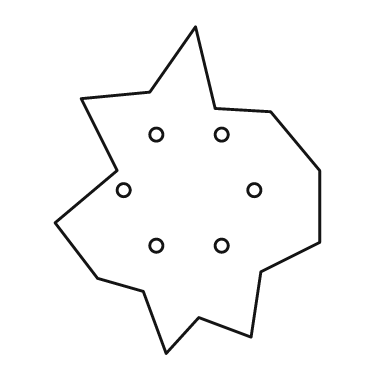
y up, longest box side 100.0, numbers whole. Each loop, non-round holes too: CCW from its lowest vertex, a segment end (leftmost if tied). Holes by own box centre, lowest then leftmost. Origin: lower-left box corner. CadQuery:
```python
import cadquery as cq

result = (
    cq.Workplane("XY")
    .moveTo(34.0, 0.0)
    .lineTo(44.0, 11.0)
    .lineTo(60.0, 5.0)
    .lineTo(63.0, 25.0)
    .lineTo(81.0, 34.0)
    .lineTo(81.0, 56.0)
    .lineTo(66.0, 74.0)
    .lineTo(49.0, 75.0)
    .lineTo(43.0, 100.0)
    .lineTo(29.0, 80.0)
    .lineTo(8.0, 78.0)
    .lineTo(19.0, 56.0)
    .lineTo(0.0, 40.0)
    .lineTo(13.0, 23.0)
    .lineTo(27.0, 19.0)
    .close()
    .moveTo(31.0, 33.0)
    .circle(2.0)
    .moveTo(51.0, 33.0)
    .circle(2.0)
    .moveTo(21.0, 50.0)
    .circle(2.0)
    .moveTo(61.0, 50.0)
    .circle(2.0)
    .moveTo(31.0, 67.0)
    .circle(2.0)
    .moveTo(51.0, 67.0)
    .circle(2.0)
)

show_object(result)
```